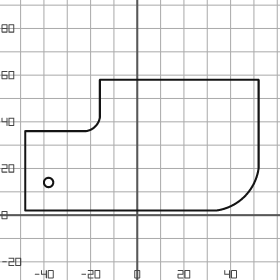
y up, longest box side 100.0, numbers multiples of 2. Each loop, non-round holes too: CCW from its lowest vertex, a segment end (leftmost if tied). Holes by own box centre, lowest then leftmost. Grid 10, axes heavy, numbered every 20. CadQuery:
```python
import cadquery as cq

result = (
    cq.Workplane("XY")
    .moveTo(-48.0, 2.0)
    .lineTo(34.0, 2.0)
    .threePointArc((46.0, 8.0), (52.0, 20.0))
    .lineTo(52.0, 58.0)
    .lineTo(-16.0, 58.0)
    .lineTo(-16.0, 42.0)
    .threePointArc((-18.0, 38.0), (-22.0, 36.0))
    .lineTo(-48.0, 36.0)
    .close()
    .moveTo(-38.0, 14.0)
    .circle(2.0)
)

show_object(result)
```